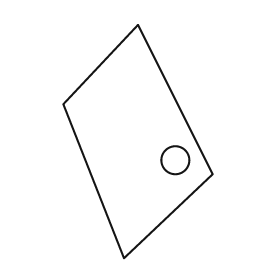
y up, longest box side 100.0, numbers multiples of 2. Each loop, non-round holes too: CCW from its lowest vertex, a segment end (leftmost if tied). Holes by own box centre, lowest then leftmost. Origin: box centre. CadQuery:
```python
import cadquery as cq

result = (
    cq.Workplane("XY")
    .moveTo(-6.0, -50.0)
    .lineTo(32.0, -14.0)
    .lineTo(0.0, 50.0)
    .lineTo(-32.0, 16.0)
    .close()
    .moveTo(16.0, -8.0)
    .circle(6.0)
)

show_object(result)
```